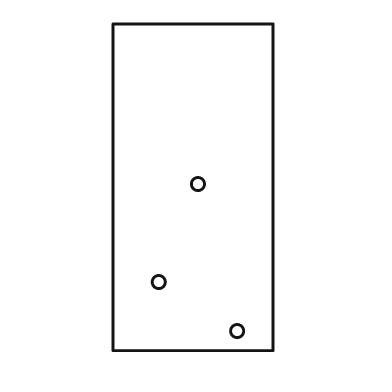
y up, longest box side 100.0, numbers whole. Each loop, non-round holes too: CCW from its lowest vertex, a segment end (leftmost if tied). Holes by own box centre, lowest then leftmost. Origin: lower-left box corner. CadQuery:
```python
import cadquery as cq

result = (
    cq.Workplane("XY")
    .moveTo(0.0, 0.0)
    .lineTo(49.0, 0.0)
    .lineTo(49.0, 100.0)
    .lineTo(0.0, 100.0)
    .close()
    .moveTo(38.0, 6.0)
    .circle(2.0)
    .moveTo(14.0, 21.0)
    .circle(2.0)
    .moveTo(26.0, 51.0)
    .circle(2.0)
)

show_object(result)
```